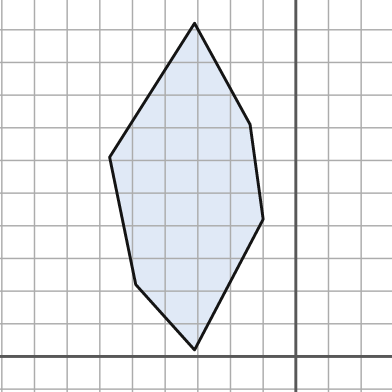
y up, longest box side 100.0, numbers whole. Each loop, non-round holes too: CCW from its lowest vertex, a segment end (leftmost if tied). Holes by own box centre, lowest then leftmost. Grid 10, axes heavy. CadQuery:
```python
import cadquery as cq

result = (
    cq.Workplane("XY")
    .moveTo(-31.0, 2.0)
    .lineTo(-10.0, 42.0)
    .lineTo(-14.0, 71.0)
    .lineTo(-31.0, 102.0)
    .lineTo(-57.0, 61.0)
    .lineTo(-49.0, 22.0)
    .close()
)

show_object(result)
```